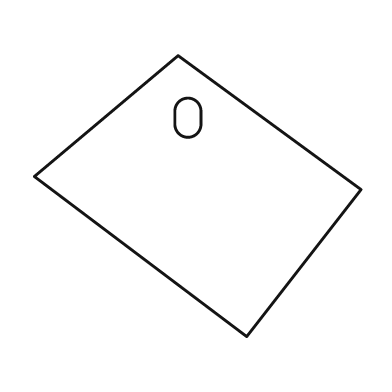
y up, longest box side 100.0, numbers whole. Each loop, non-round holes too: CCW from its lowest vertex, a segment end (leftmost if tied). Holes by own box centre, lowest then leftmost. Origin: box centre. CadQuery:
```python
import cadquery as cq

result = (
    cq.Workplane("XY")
    .moveTo(15.0, -43.0)
    .lineTo(50.0, 2.0)
    .lineTo(-6.0, 43.0)
    .lineTo(-50.0, 6.0)
    .close()
    .moveTo(-7.0, 22.0)
    .threePointArc((-3.0, 18.0), (1.0, 22.0))
    .lineTo(1.0, 26.0)
    .threePointArc((-3.0, 30.0), (-7.0, 26.0))
    .close()
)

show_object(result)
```